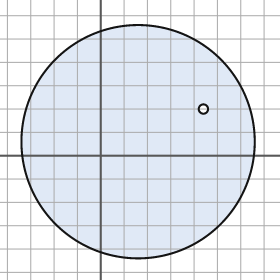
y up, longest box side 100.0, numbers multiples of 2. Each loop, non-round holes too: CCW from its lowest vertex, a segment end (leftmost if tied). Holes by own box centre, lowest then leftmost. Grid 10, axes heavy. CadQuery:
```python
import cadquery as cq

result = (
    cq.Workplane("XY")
    .moveTo(16.0, 6.0)
    .circle(50.0)
    .moveTo(44.0, 20.0)
    .circle(2.0)
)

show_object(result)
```